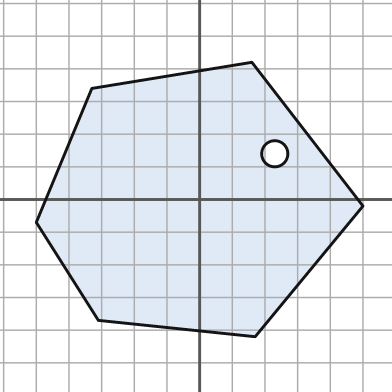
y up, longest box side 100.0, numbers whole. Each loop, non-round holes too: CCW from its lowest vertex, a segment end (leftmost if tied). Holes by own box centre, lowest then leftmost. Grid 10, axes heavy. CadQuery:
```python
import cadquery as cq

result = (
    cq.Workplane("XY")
    .moveTo(17.0, -42.0)
    .lineTo(50.0, -2.0)
    .lineTo(16.0, 42.0)
    .lineTo(-33.0, 34.0)
    .lineTo(-50.0, -7.0)
    .lineTo(-31.0, -37.0)
    .close()
    .moveTo(23.0, 14.0)
    .circle(4.0)
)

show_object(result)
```